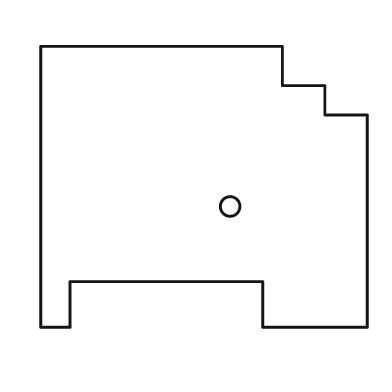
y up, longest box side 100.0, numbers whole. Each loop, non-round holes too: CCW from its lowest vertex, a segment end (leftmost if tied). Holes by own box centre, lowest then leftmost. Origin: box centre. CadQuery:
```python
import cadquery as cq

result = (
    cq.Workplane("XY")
    .moveTo(-50.0, -43.0)
    .lineTo(-41.0, -43.0)
    .lineTo(-41.0, -29.0)
    .lineTo(18.0, -29.0)
    .lineTo(18.0, -43.0)
    .lineTo(50.0, -43.0)
    .lineTo(50.0, 22.0)
    .lineTo(37.0, 22.0)
    .lineTo(37.0, 31.0)
    .lineTo(24.0, 31.0)
    .lineTo(24.0, 43.0)
    .lineTo(-50.0, 43.0)
    .close()
    .moveTo(8.0, -6.0)
    .circle(3.0)
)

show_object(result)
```